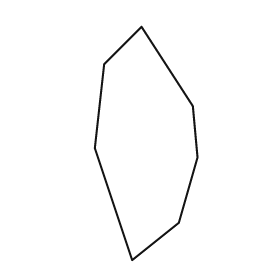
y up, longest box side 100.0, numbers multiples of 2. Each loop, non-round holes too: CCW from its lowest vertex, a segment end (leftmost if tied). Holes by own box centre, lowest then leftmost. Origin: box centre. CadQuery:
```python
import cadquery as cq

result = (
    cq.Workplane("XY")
    .moveTo(-6.0, -50.0)
    .lineTo(14.0, -34.0)
    .lineTo(22.0, -6.0)
    .lineTo(20.0, 16.0)
    .lineTo(-2.0, 50.0)
    .lineTo(-18.0, 34.0)
    .lineTo(-22.0, -2.0)
    .close()
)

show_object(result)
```